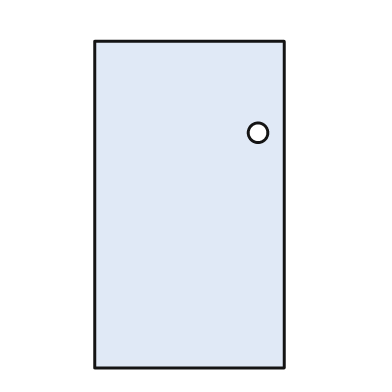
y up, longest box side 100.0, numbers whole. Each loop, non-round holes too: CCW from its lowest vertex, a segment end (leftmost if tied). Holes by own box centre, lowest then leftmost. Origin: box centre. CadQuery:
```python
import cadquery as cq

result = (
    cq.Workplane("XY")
    .moveTo(-29.0, -50.0)
    .lineTo(29.0, -50.0)
    .lineTo(29.0, 50.0)
    .lineTo(-29.0, 50.0)
    .close()
    .moveTo(21.0, 22.0)
    .circle(3.0)
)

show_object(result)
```